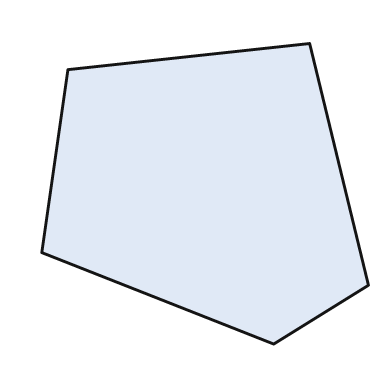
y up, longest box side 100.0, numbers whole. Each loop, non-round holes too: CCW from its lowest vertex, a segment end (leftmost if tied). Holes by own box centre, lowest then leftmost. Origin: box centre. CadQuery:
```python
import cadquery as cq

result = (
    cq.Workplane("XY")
    .moveTo(21.0, -46.0)
    .lineTo(50.0, -28.0)
    .lineTo(32.0, 46.0)
    .lineTo(-42.0, 38.0)
    .lineTo(-50.0, -18.0)
    .close()
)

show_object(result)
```